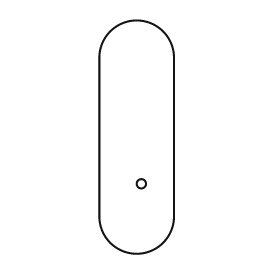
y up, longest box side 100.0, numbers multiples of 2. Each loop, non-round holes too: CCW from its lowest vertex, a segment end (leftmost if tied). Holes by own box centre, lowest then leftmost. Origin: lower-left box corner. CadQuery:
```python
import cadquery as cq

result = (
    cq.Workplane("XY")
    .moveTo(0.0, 16.0)
    .threePointArc((16.0, 0.0), (32.0, 16.0))
    .lineTo(32.0, 84.0)
    .threePointArc((16.0, 100.0), (0.0, 84.0))
    .close()
    .moveTo(18.0, 30.0)
    .circle(2.0)
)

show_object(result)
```